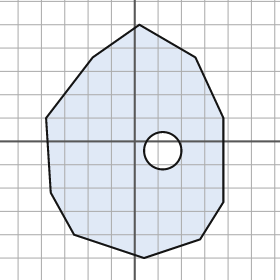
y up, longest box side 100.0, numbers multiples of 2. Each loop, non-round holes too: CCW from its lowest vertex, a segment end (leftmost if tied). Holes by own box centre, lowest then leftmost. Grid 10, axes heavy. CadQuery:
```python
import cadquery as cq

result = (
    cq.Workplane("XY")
    .moveTo(4.0, -50.0)
    .lineTo(28.0, -42.0)
    .lineTo(38.0, -26.0)
    .lineTo(38.0, 10.0)
    .lineTo(26.0, 36.0)
    .lineTo(2.0, 50.0)
    .lineTo(-18.0, 36.0)
    .lineTo(-38.0, 10.0)
    .lineTo(-36.0, -22.0)
    .lineTo(-26.0, -40.0)
    .close()
    .moveTo(12.0, -4.0)
    .circle(8.0)
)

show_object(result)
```